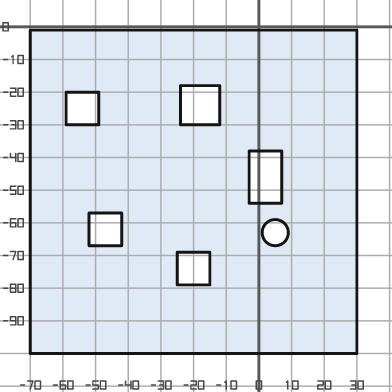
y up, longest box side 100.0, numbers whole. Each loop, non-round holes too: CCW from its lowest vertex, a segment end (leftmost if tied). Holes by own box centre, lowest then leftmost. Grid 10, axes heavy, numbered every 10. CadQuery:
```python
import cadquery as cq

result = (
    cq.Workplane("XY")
    .moveTo(-70.0, -100.0)
    .lineTo(30.0, -100.0)
    .lineTo(30.0, -1.0)
    .lineTo(-70.0, -1.0)
    .close()
    .moveTo(-25.0, -79.0)
    .lineTo(-15.0, -79.0)
    .lineTo(-15.0, -69.0)
    .lineTo(-25.0, -69.0)
    .close()
    .moveTo(5.0, -63.0)
    .circle(4.0)
    .moveTo(-52.0, -67.0)
    .lineTo(-42.0, -67.0)
    .lineTo(-42.0, -57.0)
    .lineTo(-52.0, -57.0)
    .close()
    .moveTo(-3.0, -54.0)
    .lineTo(7.0, -54.0)
    .lineTo(7.0, -38.0)
    .lineTo(-3.0, -38.0)
    .close()
    .moveTo(-59.0, -30.0)
    .lineTo(-49.0, -30.0)
    .lineTo(-49.0, -20.0)
    .lineTo(-59.0, -20.0)
    .close()
    .moveTo(-24.0, -30.0)
    .lineTo(-12.0, -30.0)
    .lineTo(-12.0, -18.0)
    .lineTo(-24.0, -18.0)
    .close()
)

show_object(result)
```